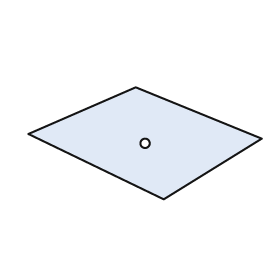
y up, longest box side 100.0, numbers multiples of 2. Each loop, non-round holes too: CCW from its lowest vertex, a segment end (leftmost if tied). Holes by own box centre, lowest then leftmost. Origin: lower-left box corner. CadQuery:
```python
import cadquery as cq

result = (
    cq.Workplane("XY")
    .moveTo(58.0, 0.0)
    .lineTo(100.0, 26.0)
    .lineTo(46.0, 48.0)
    .lineTo(0.0, 28.0)
    .close()
    .moveTo(50.0, 24.0)
    .circle(2.0)
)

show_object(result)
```